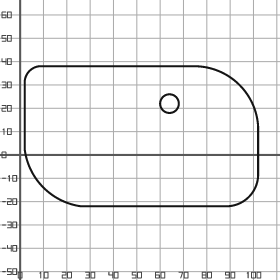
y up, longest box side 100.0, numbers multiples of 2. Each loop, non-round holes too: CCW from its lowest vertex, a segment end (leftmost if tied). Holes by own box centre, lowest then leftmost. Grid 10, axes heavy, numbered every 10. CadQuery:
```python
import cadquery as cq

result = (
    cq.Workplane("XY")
    .moveTo(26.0, -22.0)
    .lineTo(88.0, -22.0)
    .threePointArc((98.0, -18.0), (102.0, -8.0))
    .lineTo(102.0, 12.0)
    .threePointArc((94.0, 30.0), (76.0, 38.0))
    .lineTo(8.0, 38.0)
    .threePointArc((4.0, 36.0), (2.0, 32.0))
    .lineTo(2.0, 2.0)
    .threePointArc((10.0, -14.0), (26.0, -22.0))
    .close()
    .moveTo(64.0, 22.0)
    .circle(4.0)
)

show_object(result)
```